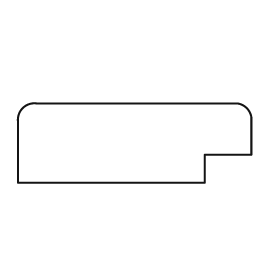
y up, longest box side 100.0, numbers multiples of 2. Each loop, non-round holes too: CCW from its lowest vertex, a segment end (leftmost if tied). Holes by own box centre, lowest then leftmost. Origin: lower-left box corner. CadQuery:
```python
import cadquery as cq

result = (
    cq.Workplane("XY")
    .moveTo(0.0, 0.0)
    .lineTo(80.0, 0.0)
    .lineTo(80.0, 12.0)
    .lineTo(100.0, 12.0)
    .lineTo(100.0, 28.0)
    .threePointArc((98.0, 32.0), (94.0, 34.0))
    .lineTo(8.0, 34.0)
    .threePointArc((2.0, 32.0), (0.0, 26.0))
    .close()
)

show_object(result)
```